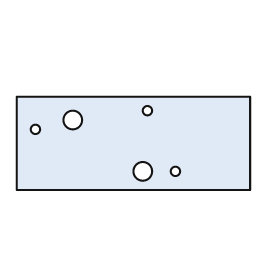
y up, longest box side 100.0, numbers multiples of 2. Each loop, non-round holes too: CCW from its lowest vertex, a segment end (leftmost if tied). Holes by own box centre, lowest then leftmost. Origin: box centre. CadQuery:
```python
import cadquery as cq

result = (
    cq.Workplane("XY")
    .moveTo(-50.0, -20.0)
    .lineTo(50.0, -20.0)
    .lineTo(50.0, 20.0)
    .lineTo(-50.0, 20.0)
    .close()
    .moveTo(4.0, -12.0)
    .circle(4.0)
    .moveTo(18.0, -12.0)
    .circle(2.0)
    .moveTo(-42.0, 6.0)
    .circle(2.0)
    .moveTo(-26.0, 10.0)
    .circle(4.0)
    .moveTo(6.0, 14.0)
    .circle(2.0)
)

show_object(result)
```